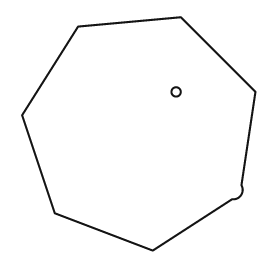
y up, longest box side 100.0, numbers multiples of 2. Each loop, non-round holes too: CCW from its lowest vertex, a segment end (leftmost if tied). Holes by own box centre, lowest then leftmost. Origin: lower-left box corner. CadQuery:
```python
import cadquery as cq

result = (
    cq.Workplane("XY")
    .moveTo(56.0, 0.0)
    .lineTo(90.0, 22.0)
    .threePointArc((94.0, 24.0), (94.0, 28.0))
    .lineTo(100.0, 68.0)
    .lineTo(68.0, 100.0)
    .lineTo(24.0, 96.0)
    .lineTo(0.0, 58.0)
    .lineTo(14.0, 16.0)
    .close()
    .moveTo(66.0, 68.0)
    .circle(2.0)
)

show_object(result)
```